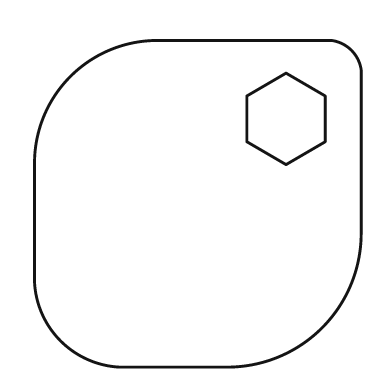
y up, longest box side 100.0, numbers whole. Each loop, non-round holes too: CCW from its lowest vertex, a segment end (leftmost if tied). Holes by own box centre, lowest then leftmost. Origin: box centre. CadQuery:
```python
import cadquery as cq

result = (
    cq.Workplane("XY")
    .moveTo(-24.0, -50.0)
    .lineTo(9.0, -50.0)
    .threePointArc((38.0, -38.0), (50.0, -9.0))
    .lineTo(50.0, 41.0)
    .threePointArc((47.0, 47.0), (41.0, 50.0))
    .lineTo(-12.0, 50.0)
    .threePointArc((-39.0, 39.0), (-50.0, 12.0))
    .lineTo(-50.0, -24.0)
    .threePointArc((-42.0, -42.0), (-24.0, -50.0))
    .close()
    .moveTo(27.0, 12.0)
    .lineTo(39.0, 19.0)
    .lineTo(39.0, 33.0)
    .lineTo(27.0, 40.0)
    .lineTo(15.0, 33.0)
    .lineTo(15.0, 19.0)
    .close()
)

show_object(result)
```